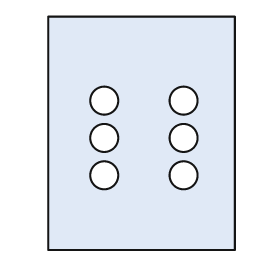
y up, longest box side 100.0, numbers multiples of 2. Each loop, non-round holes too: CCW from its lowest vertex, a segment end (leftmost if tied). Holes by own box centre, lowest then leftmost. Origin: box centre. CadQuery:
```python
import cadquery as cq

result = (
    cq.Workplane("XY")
    .moveTo(-40.0, -50.0)
    .lineTo(40.0, -50.0)
    .lineTo(40.0, 50.0)
    .lineTo(-40.0, 50.0)
    .close()
    .moveTo(-16.0, -18.0)
    .circle(6.0)
    .moveTo(18.0, -18.0)
    .circle(6.0)
    .moveTo(-16.0, -2.0)
    .circle(6.0)
    .moveTo(18.0, -2.0)
    .circle(6.0)
    .moveTo(-16.0, 14.0)
    .circle(6.0)
    .moveTo(18.0, 14.0)
    .circle(6.0)
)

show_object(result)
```